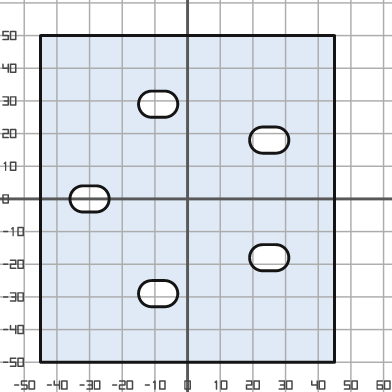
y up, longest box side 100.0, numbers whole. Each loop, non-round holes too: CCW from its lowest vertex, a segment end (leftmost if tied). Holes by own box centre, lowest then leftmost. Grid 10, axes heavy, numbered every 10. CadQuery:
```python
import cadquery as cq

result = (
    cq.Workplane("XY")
    .moveTo(-45.0, -50.0)
    .lineTo(45.0, -50.0)
    .lineTo(45.0, 50.0)
    .lineTo(-45.0, 50.0)
    .close()
    .moveTo(-11.0, -33.0)
    .lineTo(-7.0, -33.0)
    .threePointArc((-3.0, -29.0), (-7.0, -25.0))
    .lineTo(-11.0, -25.0)
    .threePointArc((-15.0, -29.0), (-11.0, -33.0))
    .close()
    .moveTo(23.0, -22.0)
    .lineTo(27.0, -22.0)
    .threePointArc((31.0, -18.0), (27.0, -14.0))
    .lineTo(23.0, -14.0)
    .threePointArc((19.0, -18.0), (23.0, -22.0))
    .close()
    .moveTo(-32.0, -4.0)
    .lineTo(-28.0, -4.0)
    .threePointArc((-24.0, 0.0), (-28.0, 4.0))
    .lineTo(-32.0, 4.0)
    .threePointArc((-36.0, 0.0), (-32.0, -4.0))
    .close()
    .moveTo(23.0, 14.0)
    .lineTo(27.0, 14.0)
    .threePointArc((31.0, 18.0), (27.0, 22.0))
    .lineTo(23.0, 22.0)
    .threePointArc((19.0, 18.0), (23.0, 14.0))
    .close()
    .moveTo(-11.0, 25.0)
    .lineTo(-7.0, 25.0)
    .threePointArc((-3.0, 29.0), (-7.0, 33.0))
    .lineTo(-11.0, 33.0)
    .threePointArc((-15.0, 29.0), (-11.0, 25.0))
    .close()
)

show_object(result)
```